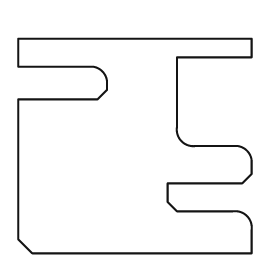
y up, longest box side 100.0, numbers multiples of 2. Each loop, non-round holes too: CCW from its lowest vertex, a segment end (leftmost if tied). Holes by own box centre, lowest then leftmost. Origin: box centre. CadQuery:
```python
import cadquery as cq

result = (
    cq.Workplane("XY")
    .moveTo(-44.0, -46.0)
    .lineTo(50.0, -46.0)
    .lineTo(50.0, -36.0)
    .threePointArc((48.0, -30.0), (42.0, -28.0))
    .lineTo(18.0, -28.0)
    .lineTo(14.0, -24.0)
    .lineTo(14.0, -16.0)
    .lineTo(46.0, -16.0)
    .lineTo(50.0, -12.0)
    .lineTo(50.0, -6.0)
    .threePointArc((48.0, -2.0), (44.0, 0.0))
    .lineTo(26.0, 0.0)
    .threePointArc((20.0, 2.0), (18.0, 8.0))
    .lineTo(18.0, 38.0)
    .lineTo(50.0, 38.0)
    .lineTo(50.0, 46.0)
    .lineTo(-50.0, 46.0)
    .lineTo(-50.0, 34.0)
    .lineTo(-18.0, 34.0)
    .threePointArc((-14.0, 32.0), (-12.0, 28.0))
    .lineTo(-12.0, 24.0)
    .lineTo(-16.0, 20.0)
    .lineTo(-50.0, 20.0)
    .lineTo(-50.0, -40.0)
    .close()
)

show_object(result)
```